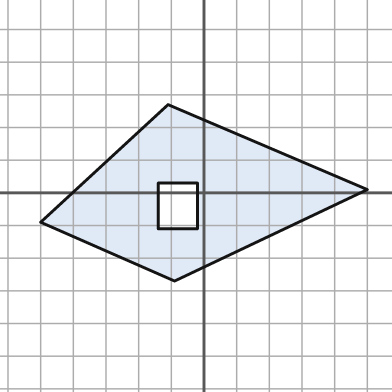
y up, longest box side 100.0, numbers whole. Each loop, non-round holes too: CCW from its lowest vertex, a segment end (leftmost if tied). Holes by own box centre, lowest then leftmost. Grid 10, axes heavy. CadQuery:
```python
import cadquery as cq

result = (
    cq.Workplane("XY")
    .moveTo(-9.0, -27.0)
    .lineTo(50.0, 1.0)
    .lineTo(-11.0, 27.0)
    .lineTo(-50.0, -9.0)
    .close()
    .moveTo(-14.0, -11.0)
    .lineTo(-2.0, -11.0)
    .lineTo(-2.0, 3.0)
    .lineTo(-14.0, 3.0)
    .close()
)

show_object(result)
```